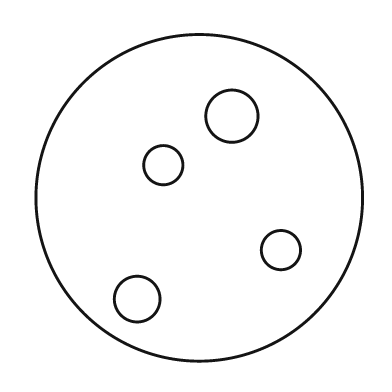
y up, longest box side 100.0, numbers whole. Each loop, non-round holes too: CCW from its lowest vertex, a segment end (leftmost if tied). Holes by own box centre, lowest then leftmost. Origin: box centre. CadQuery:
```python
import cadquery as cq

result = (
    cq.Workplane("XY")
    .moveTo(0.0, 0.0)
    .circle(50.0)
    .moveTo(-19.0, -31.0)
    .circle(7.0)
    .moveTo(25.0, -16.0)
    .circle(6.0)
    .moveTo(-11.0, 10.0)
    .circle(6.0)
    .moveTo(10.0, 25.0)
    .circle(8.0)
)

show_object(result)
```